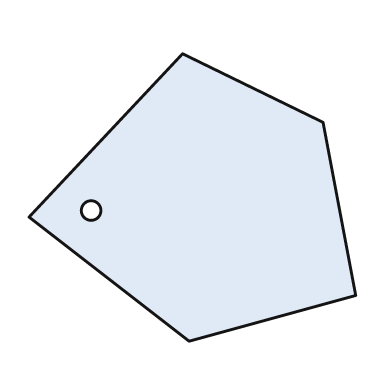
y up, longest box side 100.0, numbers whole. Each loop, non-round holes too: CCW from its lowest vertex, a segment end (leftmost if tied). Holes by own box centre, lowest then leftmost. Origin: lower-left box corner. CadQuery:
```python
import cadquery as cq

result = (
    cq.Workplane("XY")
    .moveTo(49.0, 0.0)
    .lineTo(100.0, 14.0)
    .lineTo(90.0, 67.0)
    .lineTo(47.0, 88.0)
    .lineTo(0.0, 38.0)
    .close()
    .moveTo(19.0, 40.0)
    .circle(3.0)
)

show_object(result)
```